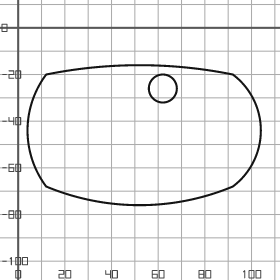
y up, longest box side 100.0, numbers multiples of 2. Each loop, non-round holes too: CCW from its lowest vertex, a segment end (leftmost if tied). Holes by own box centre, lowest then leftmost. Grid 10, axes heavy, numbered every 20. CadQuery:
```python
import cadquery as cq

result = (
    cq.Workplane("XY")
    .moveTo(12.0, -68.0)
    .threePointArc((52.0, -76.0), (92.0, -68.0))
    .threePointArc((104.0, -44.0), (92.0, -20.0))
    .threePointArc((52.0, -16.0), (12.0, -20.0))
    .threePointArc((4.0, -44.0), (12.0, -68.0))
    .close()
    .moveTo(62.0, -26.0)
    .circle(6.0)
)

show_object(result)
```